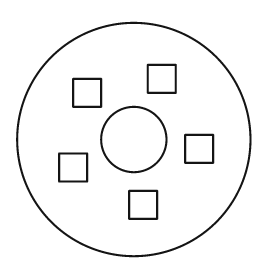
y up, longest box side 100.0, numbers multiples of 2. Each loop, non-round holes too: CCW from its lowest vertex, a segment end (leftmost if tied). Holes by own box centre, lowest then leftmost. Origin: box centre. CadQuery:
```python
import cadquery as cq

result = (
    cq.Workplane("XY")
    .moveTo(0.0, 0.0)
    .circle(50.0)
    .moveTo(-2.0, -34.0)
    .lineTo(10.0, -34.0)
    .lineTo(10.0, -22.0)
    .lineTo(-2.0, -22.0)
    .close()
    .moveTo(-32.0, -18.0)
    .lineTo(-20.0, -18.0)
    .lineTo(-20.0, -6.0)
    .lineTo(-32.0, -6.0)
    .close()
    .moveTo(22.0, -10.0)
    .lineTo(34.0, -10.0)
    .lineTo(34.0, 2.0)
    .lineTo(22.0, 2.0)
    .close()
    .moveTo(0.0, 0.0)
    .circle(14.0)
    .moveTo(-26.0, 14.0)
    .lineTo(-14.0, 14.0)
    .lineTo(-14.0, 26.0)
    .lineTo(-26.0, 26.0)
    .close()
    .moveTo(6.0, 20.0)
    .lineTo(18.0, 20.0)
    .lineTo(18.0, 32.0)
    .lineTo(6.0, 32.0)
    .close()
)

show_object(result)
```